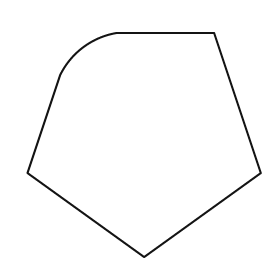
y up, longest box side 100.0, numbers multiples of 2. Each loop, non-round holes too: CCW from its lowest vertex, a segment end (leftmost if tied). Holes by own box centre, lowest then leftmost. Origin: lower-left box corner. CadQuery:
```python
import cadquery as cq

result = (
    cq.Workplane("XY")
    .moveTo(50.0, 0.0)
    .lineTo(100.0, 36.0)
    .lineTo(80.0, 96.0)
    .lineTo(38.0, 96.0)
    .threePointArc((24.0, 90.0), (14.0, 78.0))
    .lineTo(0.0, 36.0)
    .close()
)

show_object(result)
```